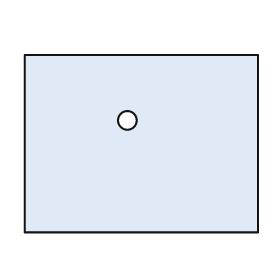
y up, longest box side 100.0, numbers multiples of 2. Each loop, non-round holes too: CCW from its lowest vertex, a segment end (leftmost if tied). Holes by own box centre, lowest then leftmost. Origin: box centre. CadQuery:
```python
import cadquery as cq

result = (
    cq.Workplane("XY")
    .moveTo(-50.0, -38.0)
    .lineTo(50.0, -38.0)
    .lineTo(50.0, 38.0)
    .lineTo(-50.0, 38.0)
    .close()
    .moveTo(-6.0, 10.0)
    .circle(4.0)
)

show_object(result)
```